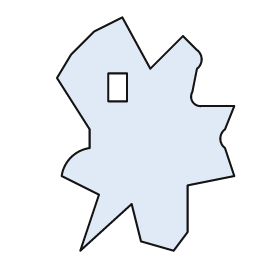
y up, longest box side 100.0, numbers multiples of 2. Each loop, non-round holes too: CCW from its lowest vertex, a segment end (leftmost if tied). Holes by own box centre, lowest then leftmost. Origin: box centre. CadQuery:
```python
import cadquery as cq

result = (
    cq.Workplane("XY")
    .moveTo(-28.0, -50.0)
    .lineTo(-6.0, -30.0)
    .lineTo(-2.0, -46.0)
    .lineTo(12.0, -50.0)
    .lineTo(18.0, -42.0)
    .lineTo(18.0, -22.0)
    .lineTo(38.0, -18.0)
    .lineTo(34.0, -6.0)
    .threePointArc((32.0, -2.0), (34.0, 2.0))
    .lineTo(38.0, 12.0)
    .lineTo(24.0, 12.0)
    .threePointArc((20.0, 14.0), (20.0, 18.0))
    .lineTo(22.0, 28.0)
    .threePointArc((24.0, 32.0), (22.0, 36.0))
    .lineTo(16.0, 42.0)
    .lineTo(2.0, 28.0)
    .lineTo(-10.0, 50.0)
    .lineTo(-22.0, 44.0)
    .lineTo(-32.0, 34.0)
    .lineTo(-38.0, 24.0)
    .lineTo(-24.0, 2.0)
    .lineTo(-24.0, -6.0)
    .threePointArc((-32.0, -10.0), (-36.0, -18.0))
    .lineTo(-20.0, -26.0)
    .close()
    .moveTo(-16.0, 14.0)
    .lineTo(-8.0, 14.0)
    .lineTo(-8.0, 26.0)
    .lineTo(-16.0, 26.0)
    .close()
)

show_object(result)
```